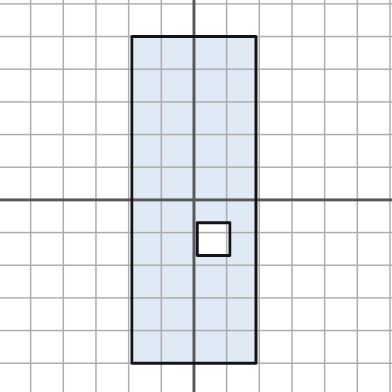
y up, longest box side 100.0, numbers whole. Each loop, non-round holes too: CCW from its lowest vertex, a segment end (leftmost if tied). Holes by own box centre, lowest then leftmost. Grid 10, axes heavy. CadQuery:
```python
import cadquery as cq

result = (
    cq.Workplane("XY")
    .moveTo(-19.0, -50.0)
    .lineTo(19.0, -50.0)
    .lineTo(19.0, 50.0)
    .lineTo(-19.0, 50.0)
    .close()
    .moveTo(1.0, -17.0)
    .lineTo(11.0, -17.0)
    .lineTo(11.0, -7.0)
    .lineTo(1.0, -7.0)
    .close()
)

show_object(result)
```